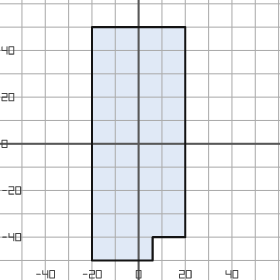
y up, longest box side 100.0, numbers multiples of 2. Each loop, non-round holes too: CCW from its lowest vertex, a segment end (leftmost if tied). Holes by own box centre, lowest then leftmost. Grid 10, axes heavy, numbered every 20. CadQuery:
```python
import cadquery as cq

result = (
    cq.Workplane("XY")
    .moveTo(-20.0, -50.0)
    .lineTo(6.0, -50.0)
    .lineTo(6.0, -40.0)
    .lineTo(20.0, -40.0)
    .lineTo(20.0, 50.0)
    .lineTo(-20.0, 50.0)
    .close()
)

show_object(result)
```